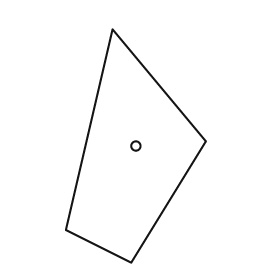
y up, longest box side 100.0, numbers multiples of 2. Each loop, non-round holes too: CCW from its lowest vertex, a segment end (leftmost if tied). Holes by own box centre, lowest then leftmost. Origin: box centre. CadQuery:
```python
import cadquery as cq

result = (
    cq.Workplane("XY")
    .moveTo(-2.0, -50.0)
    .lineTo(30.0, 2.0)
    .lineTo(-10.0, 50.0)
    .lineTo(-30.0, -36.0)
    .close()
    .moveTo(0.0, 0.0)
    .circle(2.0)
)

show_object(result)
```